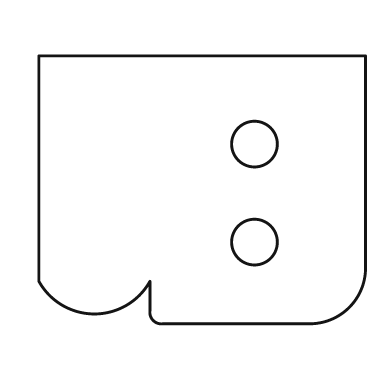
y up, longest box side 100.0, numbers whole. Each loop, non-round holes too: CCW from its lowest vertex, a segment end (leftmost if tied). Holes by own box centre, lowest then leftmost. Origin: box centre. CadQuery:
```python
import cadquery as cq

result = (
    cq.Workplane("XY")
    .moveTo(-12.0, -41.0)
    .lineTo(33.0, -41.0)
    .threePointArc((45.0, -36.0), (50.0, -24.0))
    .lineTo(50.0, 41.0)
    .lineTo(-50.0, 41.0)
    .lineTo(-50.0, -28.0)
    .threePointArc((-33.0, -38.0), (-16.0, -28.0))
    .lineTo(-16.0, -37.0)
    .threePointArc((-15.0, -40.0), (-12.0, -41.0))
    .close()
    .moveTo(16.0, -16.0)
    .circle(7.0)
    .moveTo(16.0, 14.0)
    .circle(7.0)
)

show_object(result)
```